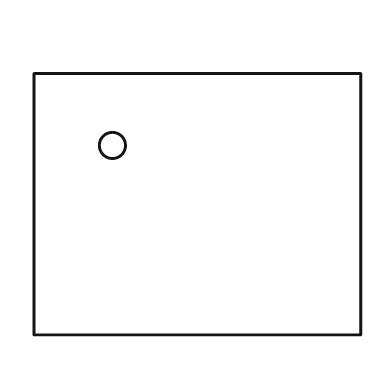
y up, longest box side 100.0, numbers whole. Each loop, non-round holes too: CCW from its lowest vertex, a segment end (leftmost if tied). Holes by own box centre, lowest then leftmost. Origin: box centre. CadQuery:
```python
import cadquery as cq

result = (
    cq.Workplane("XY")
    .moveTo(-50.0, -40.0)
    .lineTo(50.0, -40.0)
    .lineTo(50.0, 40.0)
    .lineTo(-50.0, 40.0)
    .close()
    .moveTo(-26.0, 18.0)
    .circle(4.0)
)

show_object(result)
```